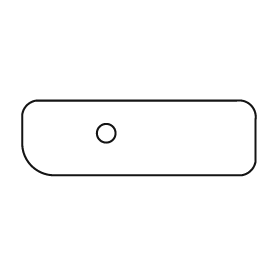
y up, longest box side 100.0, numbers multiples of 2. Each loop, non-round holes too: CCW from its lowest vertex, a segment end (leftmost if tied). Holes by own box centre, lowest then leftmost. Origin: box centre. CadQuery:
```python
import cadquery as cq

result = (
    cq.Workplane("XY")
    .moveTo(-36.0, -16.0)
    .lineTo(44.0, -16.0)
    .threePointArc((48.0, -14.0), (50.0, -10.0))
    .lineTo(50.0, 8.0)
    .threePointArc((48.0, 14.0), (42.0, 16.0))
    .lineTo(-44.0, 16.0)
    .threePointArc((-48.0, 14.0), (-50.0, 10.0))
    .lineTo(-50.0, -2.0)
    .threePointArc((-46.0, -12.0), (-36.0, -16.0))
    .close()
    .moveTo(-14.0, 2.0)
    .circle(4.0)
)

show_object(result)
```